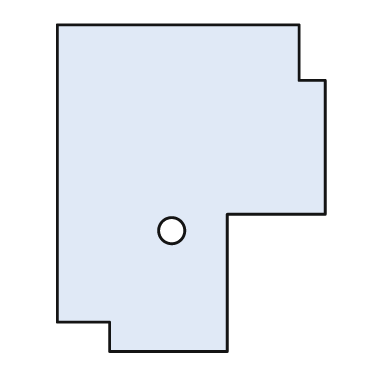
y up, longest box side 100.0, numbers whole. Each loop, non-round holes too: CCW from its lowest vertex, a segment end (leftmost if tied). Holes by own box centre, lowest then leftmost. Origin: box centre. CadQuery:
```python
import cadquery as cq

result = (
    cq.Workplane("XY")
    .moveTo(-25.0, -50.0)
    .lineTo(11.0, -50.0)
    .lineTo(11.0, -8.0)
    .lineTo(41.0, -8.0)
    .lineTo(41.0, 33.0)
    .lineTo(33.0, 33.0)
    .lineTo(33.0, 50.0)
    .lineTo(-41.0, 50.0)
    .lineTo(-41.0, -41.0)
    .lineTo(-25.0, -41.0)
    .close()
    .moveTo(-6.0, -13.0)
    .circle(4.0)
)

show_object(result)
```